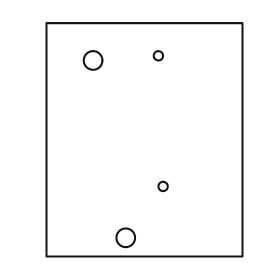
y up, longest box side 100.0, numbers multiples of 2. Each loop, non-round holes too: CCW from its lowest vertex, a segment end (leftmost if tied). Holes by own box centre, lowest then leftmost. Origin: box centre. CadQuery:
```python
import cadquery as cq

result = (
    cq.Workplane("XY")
    .moveTo(-42.0, -50.0)
    .lineTo(42.0, -50.0)
    .lineTo(42.0, 50.0)
    .lineTo(-42.0, 50.0)
    .close()
    .moveTo(-8.0, -42.0)
    .circle(4.0)
    .moveTo(8.0, -20.0)
    .circle(2.0)
    .moveTo(-22.0, 34.0)
    .circle(4.0)
    .moveTo(6.0, 36.0)
    .circle(2.0)
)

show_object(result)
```